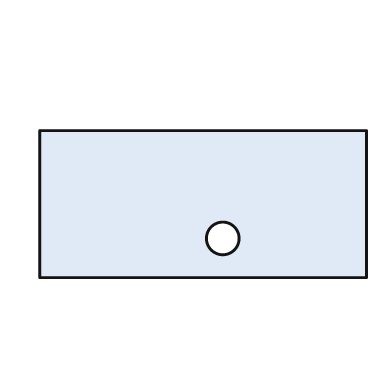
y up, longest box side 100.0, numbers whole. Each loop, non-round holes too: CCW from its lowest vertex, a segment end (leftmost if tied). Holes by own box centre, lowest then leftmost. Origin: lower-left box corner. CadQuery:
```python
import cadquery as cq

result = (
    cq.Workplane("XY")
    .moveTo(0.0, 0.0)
    .lineTo(100.0, 0.0)
    .lineTo(100.0, 45.0)
    .lineTo(0.0, 45.0)
    .close()
    .moveTo(56.0, 12.0)
    .circle(5.0)
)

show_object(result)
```